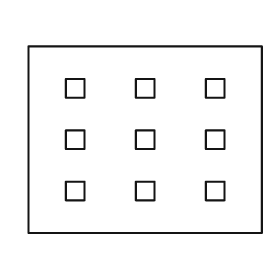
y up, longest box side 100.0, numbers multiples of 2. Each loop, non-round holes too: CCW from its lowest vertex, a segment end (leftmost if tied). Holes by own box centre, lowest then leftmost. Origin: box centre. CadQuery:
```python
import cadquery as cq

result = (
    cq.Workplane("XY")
    .moveTo(-50.0, -40.0)
    .lineTo(50.0, -40.0)
    .lineTo(50.0, 40.0)
    .lineTo(-50.0, 40.0)
    .close()
    .moveTo(-34.0, -26.0)
    .lineTo(-26.0, -26.0)
    .lineTo(-26.0, -18.0)
    .lineTo(-34.0, -18.0)
    .close()
    .moveTo(-4.0, -26.0)
    .lineTo(4.0, -26.0)
    .lineTo(4.0, -18.0)
    .lineTo(-4.0, -18.0)
    .close()
    .moveTo(26.0, -26.0)
    .lineTo(34.0, -26.0)
    .lineTo(34.0, -18.0)
    .lineTo(26.0, -18.0)
    .close()
    .moveTo(-34.0, -4.0)
    .lineTo(-26.0, -4.0)
    .lineTo(-26.0, 4.0)
    .lineTo(-34.0, 4.0)
    .close()
    .moveTo(-4.0, -4.0)
    .lineTo(4.0, -4.0)
    .lineTo(4.0, 4.0)
    .lineTo(-4.0, 4.0)
    .close()
    .moveTo(26.0, -4.0)
    .lineTo(34.0, -4.0)
    .lineTo(34.0, 4.0)
    .lineTo(26.0, 4.0)
    .close()
    .moveTo(-34.0, 18.0)
    .lineTo(-26.0, 18.0)
    .lineTo(-26.0, 26.0)
    .lineTo(-34.0, 26.0)
    .close()
    .moveTo(-4.0, 18.0)
    .lineTo(4.0, 18.0)
    .lineTo(4.0, 26.0)
    .lineTo(-4.0, 26.0)
    .close()
    .moveTo(26.0, 18.0)
    .lineTo(34.0, 18.0)
    .lineTo(34.0, 26.0)
    .lineTo(26.0, 26.0)
    .close()
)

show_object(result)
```